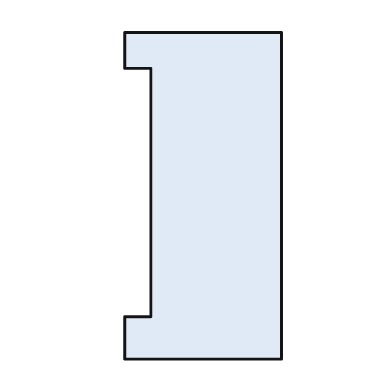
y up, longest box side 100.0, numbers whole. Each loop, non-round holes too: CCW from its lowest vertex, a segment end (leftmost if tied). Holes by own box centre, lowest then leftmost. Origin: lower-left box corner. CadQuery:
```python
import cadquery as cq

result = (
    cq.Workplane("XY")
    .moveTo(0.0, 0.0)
    .lineTo(48.0, 0.0)
    .lineTo(48.0, 100.0)
    .lineTo(0.0, 100.0)
    .lineTo(0.0, 89.0)
    .lineTo(8.0, 89.0)
    .lineTo(8.0, 13.0)
    .lineTo(0.0, 13.0)
    .close()
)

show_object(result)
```